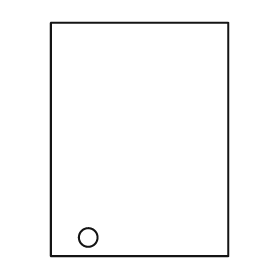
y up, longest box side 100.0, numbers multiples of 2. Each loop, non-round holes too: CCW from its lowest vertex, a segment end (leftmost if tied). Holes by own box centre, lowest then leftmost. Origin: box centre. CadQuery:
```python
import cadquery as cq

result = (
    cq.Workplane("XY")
    .moveTo(-38.0, -50.0)
    .lineTo(38.0, -50.0)
    .lineTo(38.0, 50.0)
    .lineTo(-38.0, 50.0)
    .close()
    .moveTo(-22.0, -42.0)
    .circle(4.0)
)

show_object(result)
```